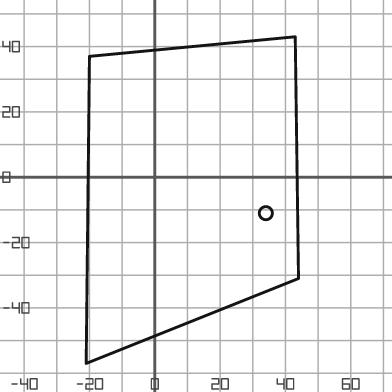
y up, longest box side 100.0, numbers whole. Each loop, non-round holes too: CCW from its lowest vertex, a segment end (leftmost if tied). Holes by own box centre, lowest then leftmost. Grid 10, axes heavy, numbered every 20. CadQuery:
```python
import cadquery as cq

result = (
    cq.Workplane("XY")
    .moveTo(-21.0, -57.0)
    .lineTo(44.0, -31.0)
    .lineTo(43.0, 43.0)
    .lineTo(-20.0, 37.0)
    .close()
    .moveTo(34.0, -11.0)
    .circle(2.0)
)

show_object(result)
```